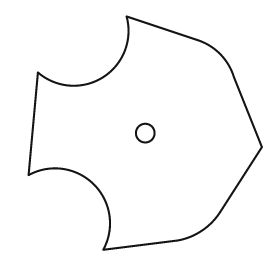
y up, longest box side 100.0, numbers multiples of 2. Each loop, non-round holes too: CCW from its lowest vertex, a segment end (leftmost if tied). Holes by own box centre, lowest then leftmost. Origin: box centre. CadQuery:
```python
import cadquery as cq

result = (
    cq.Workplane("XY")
    .moveTo(-18.0, -50.0)
    .lineTo(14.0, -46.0)
    .threePointArc((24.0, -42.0), (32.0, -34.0))
    .lineTo(50.0, -6.0)
    .lineTo(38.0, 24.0)
    .threePointArc((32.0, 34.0), (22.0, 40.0))
    .lineTo(-8.0, 50.0)
    .threePointArc((-18.0, 24.0), (-46.0, 26.0))
    .lineTo(-50.0, -18.0)
    .threePointArc((-22.0, -22.0), (-18.0, -50.0))
    .close()
    .moveTo(0.0, 0.0)
    .circle(4.0)
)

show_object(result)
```